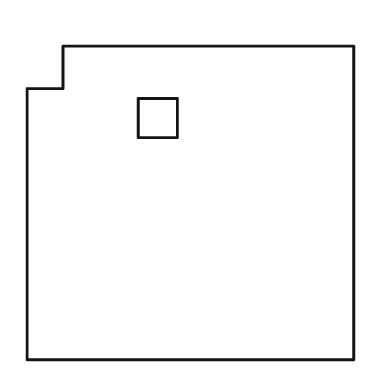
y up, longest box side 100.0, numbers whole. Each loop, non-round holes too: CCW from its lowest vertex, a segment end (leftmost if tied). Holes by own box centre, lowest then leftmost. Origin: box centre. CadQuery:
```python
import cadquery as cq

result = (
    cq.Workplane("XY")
    .moveTo(-50.0, -48.0)
    .lineTo(50.0, -48.0)
    .lineTo(50.0, 48.0)
    .lineTo(-39.0, 48.0)
    .lineTo(-39.0, 35.0)
    .lineTo(-50.0, 35.0)
    .close()
    .moveTo(-16.0, 20.0)
    .lineTo(-4.0, 20.0)
    .lineTo(-4.0, 32.0)
    .lineTo(-16.0, 32.0)
    .close()
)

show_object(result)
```